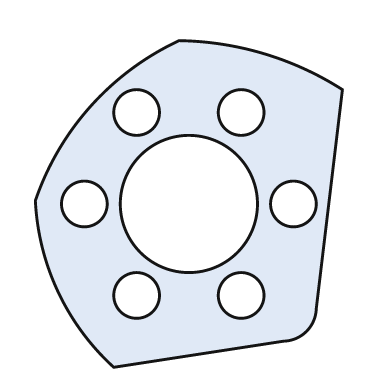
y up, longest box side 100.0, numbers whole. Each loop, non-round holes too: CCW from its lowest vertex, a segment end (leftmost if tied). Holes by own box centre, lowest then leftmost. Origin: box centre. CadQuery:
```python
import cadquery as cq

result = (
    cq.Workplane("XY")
    .moveTo(-23.0, -50.0)
    .lineTo(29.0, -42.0)
    .threePointArc((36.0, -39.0), (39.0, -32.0))
    .lineTo(47.0, 35.0)
    .threePointArc((23.0, 46.0), (-3.0, 50.0))
    .threePointArc((-30.0, 30.0), (-47.0, 1.0))
    .threePointArc((-40.0, -27.0), (-23.0, -50.0))
    .close()
    .moveTo(-16.0, -28.0)
    .circle(7.0)
    .moveTo(16.0, -28.0)
    .circle(7.0)
    .moveTo(-32.0, 0.0)
    .circle(7.0)
    .moveTo(0.0, 0.0)
    .circle(21.0)
    .moveTo(32.0, 0.0)
    .circle(7.0)
    .moveTo(-16.0, 28.0)
    .circle(7.0)
    .moveTo(16.0, 28.0)
    .circle(7.0)
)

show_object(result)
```